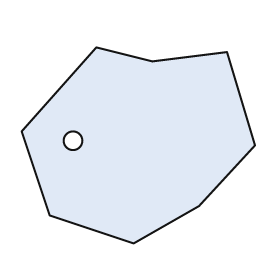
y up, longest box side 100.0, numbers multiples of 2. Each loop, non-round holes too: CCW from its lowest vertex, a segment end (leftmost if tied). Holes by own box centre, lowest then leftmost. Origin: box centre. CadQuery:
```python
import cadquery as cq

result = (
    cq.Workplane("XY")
    .moveTo(-2.0, -42.0)
    .lineTo(26.0, -26.0)
    .lineTo(50.0, 0.0)
    .lineTo(38.0, 40.0)
    .lineTo(6.0, 36.0)
    .lineTo(-18.0, 42.0)
    .lineTo(-50.0, 6.0)
    .lineTo(-38.0, -30.0)
    .close()
    .moveTo(-28.0, 2.0)
    .circle(4.0)
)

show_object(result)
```